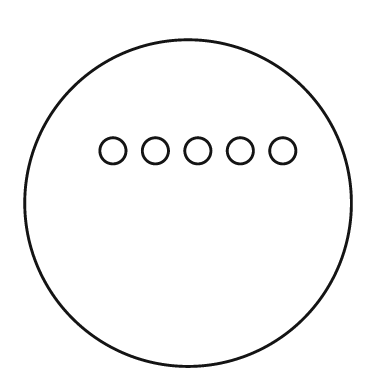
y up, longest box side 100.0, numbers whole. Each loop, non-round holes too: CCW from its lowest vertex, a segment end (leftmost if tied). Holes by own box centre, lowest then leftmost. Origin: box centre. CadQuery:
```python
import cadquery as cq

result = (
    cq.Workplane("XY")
    .moveTo(0.0, 0.0)
    .circle(50.0)
    .moveTo(-23.0, 16.0)
    .circle(4.0)
    .moveTo(-10.0, 16.0)
    .circle(4.0)
    .moveTo(3.0, 16.0)
    .circle(4.0)
    .moveTo(16.0, 16.0)
    .circle(4.0)
    .moveTo(29.0, 16.0)
    .circle(4.0)
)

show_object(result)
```